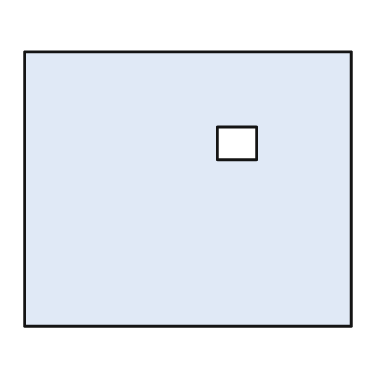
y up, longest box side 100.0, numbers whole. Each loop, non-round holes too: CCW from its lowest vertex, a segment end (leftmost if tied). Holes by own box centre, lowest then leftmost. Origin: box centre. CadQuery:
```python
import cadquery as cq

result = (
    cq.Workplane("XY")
    .moveTo(-50.0, -42.0)
    .lineTo(50.0, -42.0)
    .lineTo(50.0, 42.0)
    .lineTo(-50.0, 42.0)
    .close()
    .moveTo(9.0, 9.0)
    .lineTo(21.0, 9.0)
    .lineTo(21.0, 19.0)
    .lineTo(9.0, 19.0)
    .close()
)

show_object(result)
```